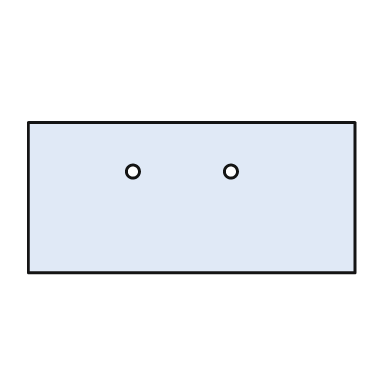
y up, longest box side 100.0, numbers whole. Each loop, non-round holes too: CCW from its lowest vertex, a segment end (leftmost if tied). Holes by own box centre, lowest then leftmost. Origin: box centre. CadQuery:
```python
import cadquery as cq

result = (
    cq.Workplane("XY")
    .moveTo(-50.0, -23.0)
    .lineTo(50.0, -23.0)
    .lineTo(50.0, 23.0)
    .lineTo(-50.0, 23.0)
    .close()
    .moveTo(-18.0, 8.0)
    .circle(2.0)
    .moveTo(12.0, 8.0)
    .circle(2.0)
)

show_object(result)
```